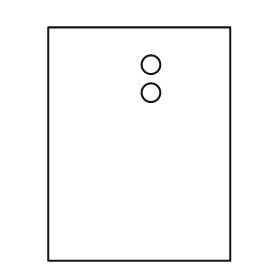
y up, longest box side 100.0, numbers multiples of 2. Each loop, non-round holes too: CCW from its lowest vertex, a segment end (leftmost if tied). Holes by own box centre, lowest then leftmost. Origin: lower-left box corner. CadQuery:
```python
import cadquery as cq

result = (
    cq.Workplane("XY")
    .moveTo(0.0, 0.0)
    .lineTo(78.0, 0.0)
    .lineTo(78.0, 100.0)
    .lineTo(0.0, 100.0)
    .close()
    .moveTo(44.0, 72.0)
    .circle(4.0)
    .moveTo(44.0, 84.0)
    .circle(4.0)
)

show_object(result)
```